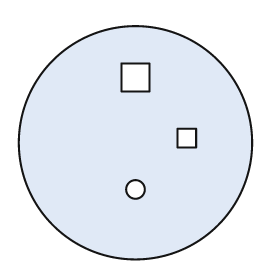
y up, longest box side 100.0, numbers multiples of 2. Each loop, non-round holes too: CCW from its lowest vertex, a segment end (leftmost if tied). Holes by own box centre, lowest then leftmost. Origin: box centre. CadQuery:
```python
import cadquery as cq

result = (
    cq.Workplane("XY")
    .moveTo(0.0, 0.0)
    .circle(50.0)
    .moveTo(0.0, -20.0)
    .circle(4.0)
    .moveTo(18.0, -2.0)
    .lineTo(26.0, -2.0)
    .lineTo(26.0, 6.0)
    .lineTo(18.0, 6.0)
    .close()
    .moveTo(-6.0, 22.0)
    .lineTo(6.0, 22.0)
    .lineTo(6.0, 34.0)
    .lineTo(-6.0, 34.0)
    .close()
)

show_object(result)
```